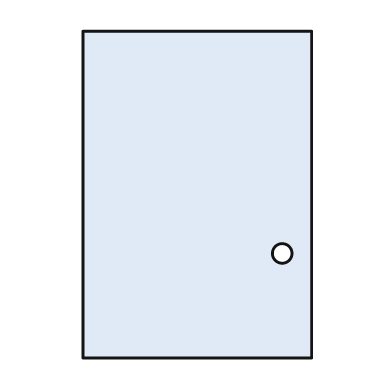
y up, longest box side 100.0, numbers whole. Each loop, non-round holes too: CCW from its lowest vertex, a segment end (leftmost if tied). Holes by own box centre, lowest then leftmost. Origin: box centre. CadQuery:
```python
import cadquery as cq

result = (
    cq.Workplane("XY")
    .moveTo(-35.0, -50.0)
    .lineTo(35.0, -50.0)
    .lineTo(35.0, 50.0)
    .lineTo(-35.0, 50.0)
    .close()
    .moveTo(26.0, -18.0)
    .circle(3.0)
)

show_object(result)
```